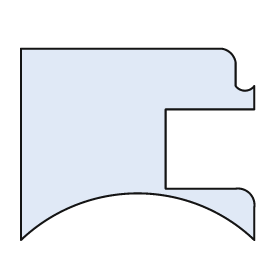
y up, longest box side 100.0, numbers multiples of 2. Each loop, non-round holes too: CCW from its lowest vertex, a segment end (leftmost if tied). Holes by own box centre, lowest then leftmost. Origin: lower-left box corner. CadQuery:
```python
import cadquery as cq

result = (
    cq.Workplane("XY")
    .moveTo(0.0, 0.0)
    .threePointArc((50.0, 20.0), (100.0, 0.0))
    .lineTo(100.0, 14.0)
    .threePointArc((98.0, 20.0), (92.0, 22.0))
    .lineTo(62.0, 22.0)
    .lineTo(62.0, 56.0)
    .lineTo(100.0, 56.0)
    .lineTo(100.0, 66.0)
    .threePointArc((96.0, 64.0), (92.0, 66.0))
    .lineTo(92.0, 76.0)
    .threePointArc((90.0, 80.0), (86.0, 82.0))
    .lineTo(0.0, 82.0)
    .close()
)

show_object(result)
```